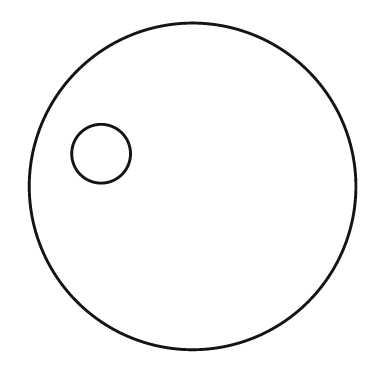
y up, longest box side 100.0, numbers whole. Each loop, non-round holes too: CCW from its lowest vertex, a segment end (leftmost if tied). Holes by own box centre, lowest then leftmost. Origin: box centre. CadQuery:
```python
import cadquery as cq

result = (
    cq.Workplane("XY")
    .moveTo(0.0, 0.0)
    .circle(50.0)
    .moveTo(-28.0, 10.0)
    .circle(9.0)
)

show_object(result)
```